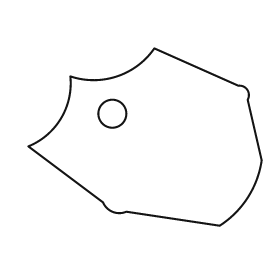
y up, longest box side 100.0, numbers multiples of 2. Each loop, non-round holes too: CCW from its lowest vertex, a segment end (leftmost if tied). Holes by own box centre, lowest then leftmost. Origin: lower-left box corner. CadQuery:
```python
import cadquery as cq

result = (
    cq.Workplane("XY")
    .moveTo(82.0, 0.0)
    .threePointArc((94.0, 12.0), (100.0, 28.0))
    .lineTo(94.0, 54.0)
    .threePointArc((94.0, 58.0), (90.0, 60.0))
    .lineTo(54.0, 76.0)
    .threePointArc((38.0, 64.0), (18.0, 64.0))
    .threePointArc((14.0, 46.0), (0.0, 34.0))
    .lineTo(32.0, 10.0)
    .threePointArc((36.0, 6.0), (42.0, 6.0))
    .close()
    .moveTo(36.0, 48.0)
    .circle(6.0)
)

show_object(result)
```